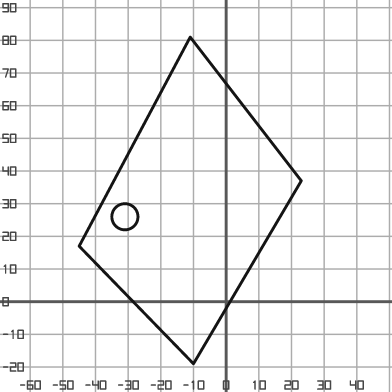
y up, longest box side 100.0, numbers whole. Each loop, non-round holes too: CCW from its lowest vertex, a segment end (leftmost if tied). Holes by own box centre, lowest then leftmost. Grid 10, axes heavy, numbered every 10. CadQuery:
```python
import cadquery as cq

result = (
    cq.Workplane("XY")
    .moveTo(-10.0, -19.0)
    .lineTo(23.0, 37.0)
    .lineTo(-11.0, 81.0)
    .lineTo(-45.0, 17.0)
    .close()
    .moveTo(-31.0, 26.0)
    .circle(4.0)
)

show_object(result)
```